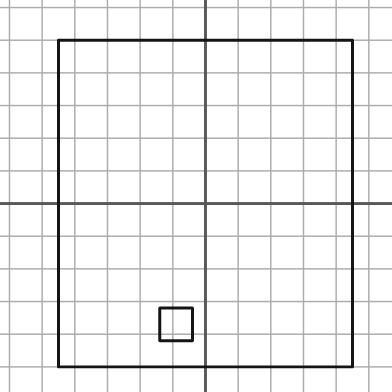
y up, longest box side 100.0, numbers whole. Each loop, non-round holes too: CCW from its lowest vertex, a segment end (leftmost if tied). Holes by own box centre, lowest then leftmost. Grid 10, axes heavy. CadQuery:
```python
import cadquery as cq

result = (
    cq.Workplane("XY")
    .moveTo(-45.0, -50.0)
    .lineTo(45.0, -50.0)
    .lineTo(45.0, 50.0)
    .lineTo(-45.0, 50.0)
    .close()
    .moveTo(-14.0, -42.0)
    .lineTo(-4.0, -42.0)
    .lineTo(-4.0, -32.0)
    .lineTo(-14.0, -32.0)
    .close()
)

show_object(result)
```